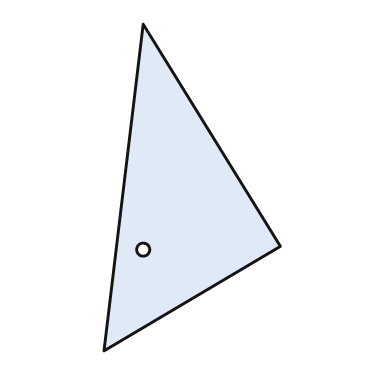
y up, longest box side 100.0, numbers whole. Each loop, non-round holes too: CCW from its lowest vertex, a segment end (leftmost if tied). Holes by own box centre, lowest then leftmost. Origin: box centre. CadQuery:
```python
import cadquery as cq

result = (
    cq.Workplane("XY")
    .moveTo(-27.0, -50.0)
    .lineTo(27.0, -18.0)
    .lineTo(-15.0, 50.0)
    .close()
    .moveTo(-15.0, -19.0)
    .circle(2.0)
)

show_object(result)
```